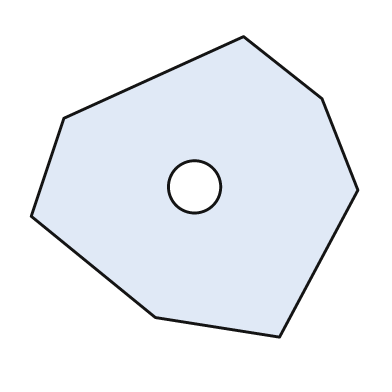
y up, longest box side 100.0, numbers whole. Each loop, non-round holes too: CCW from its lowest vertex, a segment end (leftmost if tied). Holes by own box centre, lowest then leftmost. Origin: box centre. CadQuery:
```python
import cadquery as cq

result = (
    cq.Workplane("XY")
    .moveTo(26.0, -46.0)
    .lineTo(50.0, -1.0)
    .lineTo(39.0, 27.0)
    .lineTo(15.0, 46.0)
    .lineTo(-40.0, 21.0)
    .lineTo(-50.0, -9.0)
    .lineTo(-12.0, -40.0)
    .close()
    .moveTo(0.0, 0.0)
    .circle(8.0)
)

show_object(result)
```